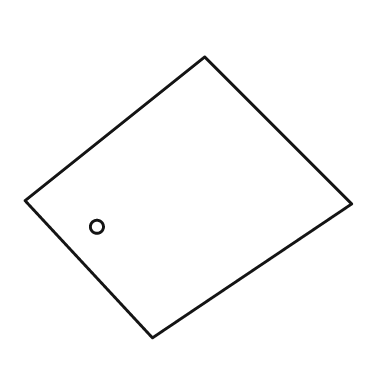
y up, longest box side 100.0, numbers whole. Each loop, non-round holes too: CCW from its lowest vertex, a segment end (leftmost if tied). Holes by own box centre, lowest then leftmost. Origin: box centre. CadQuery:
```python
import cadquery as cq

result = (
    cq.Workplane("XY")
    .moveTo(-11.0, -43.0)
    .lineTo(50.0, -2.0)
    .lineTo(5.0, 43.0)
    .lineTo(-50.0, -1.0)
    .close()
    .moveTo(-28.0, -9.0)
    .circle(2.0)
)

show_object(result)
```